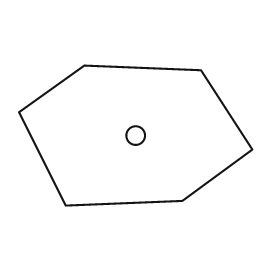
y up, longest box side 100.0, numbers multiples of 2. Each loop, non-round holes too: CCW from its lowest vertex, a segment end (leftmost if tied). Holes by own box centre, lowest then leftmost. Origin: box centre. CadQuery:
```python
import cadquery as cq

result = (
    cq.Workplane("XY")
    .moveTo(-30.0, -30.0)
    .lineTo(20.0, -28.0)
    .lineTo(50.0, -6.0)
    .lineTo(28.0, 28.0)
    .lineTo(-22.0, 30.0)
    .lineTo(-50.0, 10.0)
    .close()
    .moveTo(0.0, 0.0)
    .circle(4.0)
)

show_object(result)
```